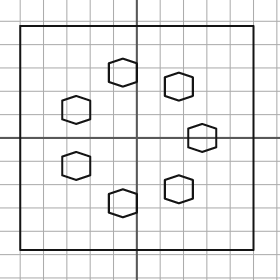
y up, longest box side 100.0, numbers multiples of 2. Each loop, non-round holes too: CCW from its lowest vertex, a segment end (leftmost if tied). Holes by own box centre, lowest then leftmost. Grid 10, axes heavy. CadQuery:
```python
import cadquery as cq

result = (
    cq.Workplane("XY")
    .moveTo(-50.0, -48.0)
    .lineTo(50.0, -48.0)
    .lineTo(50.0, 48.0)
    .lineTo(-50.0, 48.0)
    .close()
    .moveTo(-6.0, -34.0)
    .lineTo(0.0, -32.0)
    .lineTo(0.0, -24.0)
    .lineTo(-6.0, -22.0)
    .lineTo(-12.0, -24.0)
    .lineTo(-12.0, -32.0)
    .close()
    .moveTo(18.0, -28.0)
    .lineTo(24.0, -26.0)
    .lineTo(24.0, -18.0)
    .lineTo(18.0, -16.0)
    .lineTo(12.0, -18.0)
    .lineTo(12.0, -26.0)
    .close()
    .moveTo(-26.0, -18.0)
    .lineTo(-20.0, -16.0)
    .lineTo(-20.0, -8.0)
    .lineTo(-26.0, -6.0)
    .lineTo(-32.0, -8.0)
    .lineTo(-32.0, -16.0)
    .close()
    .moveTo(28.0, -6.0)
    .lineTo(34.0, -4.0)
    .lineTo(34.0, 4.0)
    .lineTo(28.0, 6.0)
    .lineTo(22.0, 4.0)
    .lineTo(22.0, -4.0)
    .close()
    .moveTo(-26.0, 6.0)
    .lineTo(-20.0, 8.0)
    .lineTo(-20.0, 16.0)
    .lineTo(-26.0, 18.0)
    .lineTo(-32.0, 16.0)
    .lineTo(-32.0, 8.0)
    .close()
    .moveTo(18.0, 16.0)
    .lineTo(24.0, 18.0)
    .lineTo(24.0, 26.0)
    .lineTo(18.0, 28.0)
    .lineTo(12.0, 26.0)
    .lineTo(12.0, 18.0)
    .close()
    .moveTo(-6.0, 22.0)
    .lineTo(0.0, 24.0)
    .lineTo(0.0, 32.0)
    .lineTo(-6.0, 34.0)
    .lineTo(-12.0, 32.0)
    .lineTo(-12.0, 24.0)
    .close()
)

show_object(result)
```